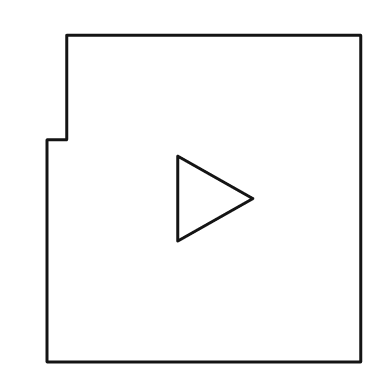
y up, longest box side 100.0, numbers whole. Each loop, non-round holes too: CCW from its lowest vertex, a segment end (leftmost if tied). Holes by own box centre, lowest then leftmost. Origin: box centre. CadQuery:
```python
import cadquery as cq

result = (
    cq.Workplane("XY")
    .moveTo(-48.0, -50.0)
    .lineTo(48.0, -50.0)
    .lineTo(48.0, 50.0)
    .lineTo(-42.0, 50.0)
    .lineTo(-42.0, 18.0)
    .lineTo(-48.0, 18.0)
    .close()
    .moveTo(-8.0, -13.0)
    .lineTo(15.0, 0.0)
    .lineTo(-8.0, 13.0)
    .close()
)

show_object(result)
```